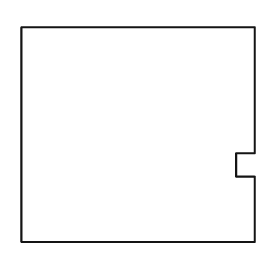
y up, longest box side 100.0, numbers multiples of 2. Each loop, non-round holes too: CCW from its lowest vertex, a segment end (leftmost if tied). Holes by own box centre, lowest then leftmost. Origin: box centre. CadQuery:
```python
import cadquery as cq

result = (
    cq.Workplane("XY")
    .moveTo(-50.0, -46.0)
    .lineTo(50.0, -46.0)
    .lineTo(50.0, -18.0)
    .lineTo(42.0, -18.0)
    .lineTo(42.0, -8.0)
    .lineTo(50.0, -8.0)
    .lineTo(50.0, 46.0)
    .lineTo(-50.0, 46.0)
    .close()
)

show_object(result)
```